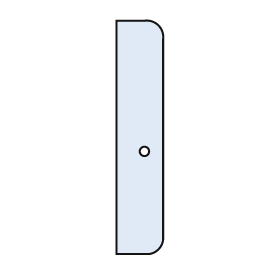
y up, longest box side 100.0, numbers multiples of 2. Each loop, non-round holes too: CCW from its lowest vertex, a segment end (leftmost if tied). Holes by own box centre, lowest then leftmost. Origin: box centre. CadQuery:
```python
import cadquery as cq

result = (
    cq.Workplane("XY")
    .moveTo(-10.0, -50.0)
    .lineTo(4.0, -50.0)
    .threePointArc((8.0, -48.0), (10.0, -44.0))
    .lineTo(10.0, 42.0)
    .threePointArc((8.0, 48.0), (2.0, 50.0))
    .lineTo(-10.0, 50.0)
    .close()
    .moveTo(2.0, -6.0)
    .circle(2.0)
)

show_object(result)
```